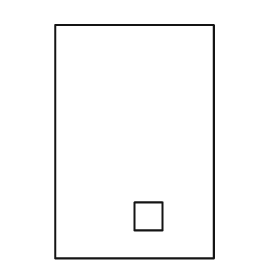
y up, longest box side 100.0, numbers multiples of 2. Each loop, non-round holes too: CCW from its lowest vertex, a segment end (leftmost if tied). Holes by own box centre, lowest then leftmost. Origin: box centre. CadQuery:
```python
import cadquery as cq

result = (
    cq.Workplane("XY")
    .moveTo(-34.0, -50.0)
    .lineTo(34.0, -50.0)
    .lineTo(34.0, 50.0)
    .lineTo(-34.0, 50.0)
    .close()
    .moveTo(0.0, -38.0)
    .lineTo(12.0, -38.0)
    .lineTo(12.0, -26.0)
    .lineTo(0.0, -26.0)
    .close()
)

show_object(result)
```